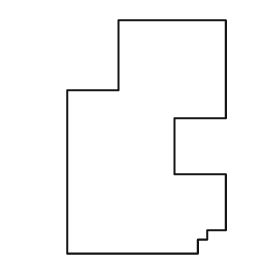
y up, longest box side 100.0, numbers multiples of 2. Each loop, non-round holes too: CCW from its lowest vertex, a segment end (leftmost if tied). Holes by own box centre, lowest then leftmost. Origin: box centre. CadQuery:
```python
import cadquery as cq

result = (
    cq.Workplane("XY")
    .moveTo(-34.0, -50.0)
    .lineTo(22.0, -50.0)
    .lineTo(22.0, -44.0)
    .lineTo(26.0, -44.0)
    .lineTo(26.0, -40.0)
    .lineTo(34.0, -40.0)
    .lineTo(34.0, -16.0)
    .lineTo(12.0, -16.0)
    .lineTo(12.0, 8.0)
    .lineTo(34.0, 8.0)
    .lineTo(34.0, 50.0)
    .lineTo(-12.0, 50.0)
    .lineTo(-12.0, 20.0)
    .lineTo(-34.0, 20.0)
    .close()
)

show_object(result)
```